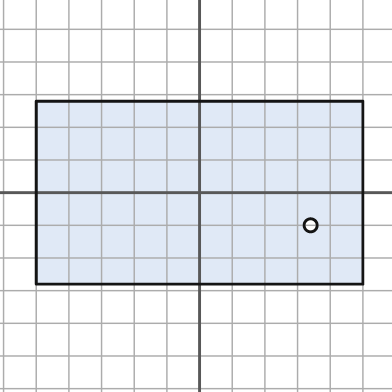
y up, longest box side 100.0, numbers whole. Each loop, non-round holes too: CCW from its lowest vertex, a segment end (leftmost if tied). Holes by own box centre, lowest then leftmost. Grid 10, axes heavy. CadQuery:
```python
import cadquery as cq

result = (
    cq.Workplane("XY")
    .moveTo(-50.0, -28.0)
    .lineTo(50.0, -28.0)
    .lineTo(50.0, 28.0)
    .lineTo(-50.0, 28.0)
    .close()
    .moveTo(34.0, -10.0)
    .circle(2.0)
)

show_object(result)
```